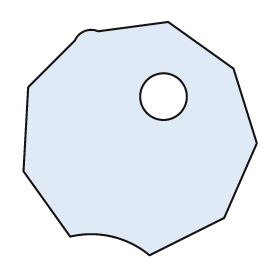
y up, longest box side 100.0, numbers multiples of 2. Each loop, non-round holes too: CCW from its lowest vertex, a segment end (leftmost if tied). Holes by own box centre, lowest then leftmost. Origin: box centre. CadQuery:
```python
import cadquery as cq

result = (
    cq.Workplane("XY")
    .moveTo(4.0, -50.0)
    .lineTo(36.0, -34.0)
    .lineTo(50.0, -2.0)
    .lineTo(40.0, 30.0)
    .lineTo(12.0, 50.0)
    .lineTo(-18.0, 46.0)
    .threePointArc((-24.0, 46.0), (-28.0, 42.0))
    .lineTo(-48.0, 22.0)
    .lineTo(-50.0, -14.0)
    .lineTo(-30.0, -42.0)
    .threePointArc((-12.0, -42.0), (4.0, -50.0))
    .close()
    .moveTo(10.0, 18.0)
    .circle(10.0)
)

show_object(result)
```